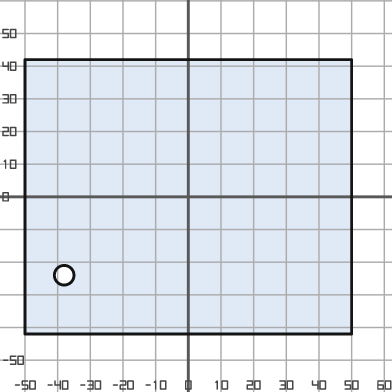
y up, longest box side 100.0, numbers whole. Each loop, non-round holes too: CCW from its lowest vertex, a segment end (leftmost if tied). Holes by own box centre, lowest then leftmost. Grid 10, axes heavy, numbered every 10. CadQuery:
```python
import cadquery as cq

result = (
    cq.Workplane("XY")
    .moveTo(-50.0, -42.0)
    .lineTo(50.0, -42.0)
    .lineTo(50.0, 42.0)
    .lineTo(-50.0, 42.0)
    .close()
    .moveTo(-38.0, -24.0)
    .circle(3.0)
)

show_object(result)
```